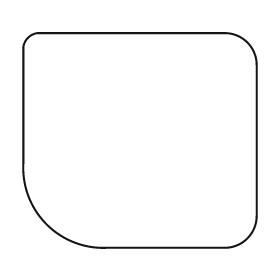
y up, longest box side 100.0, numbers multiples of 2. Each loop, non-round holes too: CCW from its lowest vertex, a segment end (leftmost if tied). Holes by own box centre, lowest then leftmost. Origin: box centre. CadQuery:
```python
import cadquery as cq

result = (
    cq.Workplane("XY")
    .moveTo(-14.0, -46.0)
    .lineTo(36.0, -46.0)
    .threePointArc((46.0, -42.0), (50.0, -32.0))
    .lineTo(50.0, 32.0)
    .threePointArc((46.0, 42.0), (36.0, 46.0))
    .lineTo(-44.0, 46.0)
    .threePointArc((-48.0, 44.0), (-50.0, 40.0))
    .lineTo(-50.0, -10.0)
    .threePointArc((-40.0, -36.0), (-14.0, -46.0))
    .close()
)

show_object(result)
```